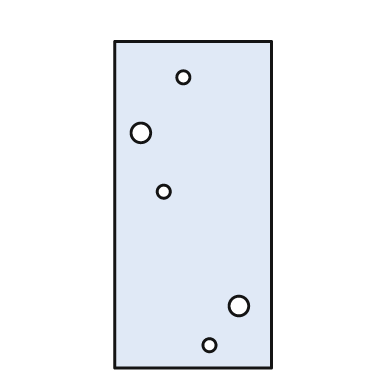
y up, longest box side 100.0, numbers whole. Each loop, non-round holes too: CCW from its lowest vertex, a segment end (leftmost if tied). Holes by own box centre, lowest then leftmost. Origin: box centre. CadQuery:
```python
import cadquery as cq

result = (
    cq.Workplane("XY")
    .moveTo(-24.0, -50.0)
    .lineTo(24.0, -50.0)
    .lineTo(24.0, 50.0)
    .lineTo(-24.0, 50.0)
    .close()
    .moveTo(5.0, -43.0)
    .circle(2.0)
    .moveTo(14.0, -31.0)
    .circle(3.0)
    .moveTo(-9.0, 4.0)
    .circle(2.0)
    .moveTo(-16.0, 22.0)
    .circle(3.0)
    .moveTo(-3.0, 39.0)
    .circle(2.0)
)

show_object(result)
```